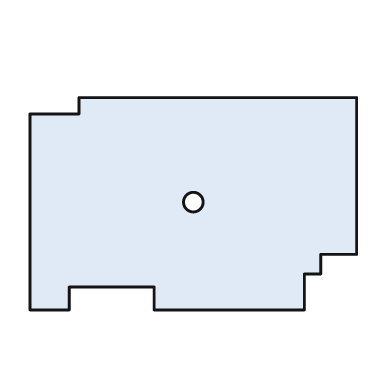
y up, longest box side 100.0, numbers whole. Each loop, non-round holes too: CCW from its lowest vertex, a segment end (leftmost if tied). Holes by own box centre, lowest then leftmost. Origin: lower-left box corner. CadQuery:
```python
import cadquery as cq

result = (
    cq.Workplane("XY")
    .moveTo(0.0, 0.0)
    .lineTo(12.0, 0.0)
    .lineTo(12.0, 7.0)
    .lineTo(38.0, 7.0)
    .lineTo(38.0, 0.0)
    .lineTo(84.0, 0.0)
    .lineTo(84.0, 11.0)
    .lineTo(89.0, 11.0)
    .lineTo(89.0, 17.0)
    .lineTo(100.0, 17.0)
    .lineTo(100.0, 65.0)
    .lineTo(15.0, 65.0)
    .lineTo(15.0, 60.0)
    .lineTo(0.0, 60.0)
    .close()
    .moveTo(50.0, 33.0)
    .circle(3.0)
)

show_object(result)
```